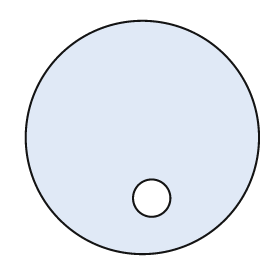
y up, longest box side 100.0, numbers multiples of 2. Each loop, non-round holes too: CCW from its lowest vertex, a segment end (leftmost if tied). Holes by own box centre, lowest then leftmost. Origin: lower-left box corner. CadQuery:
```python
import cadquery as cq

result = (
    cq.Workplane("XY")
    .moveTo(50.0, 50.0)
    .circle(50.0)
    .moveTo(54.0, 24.0)
    .circle(8.0)
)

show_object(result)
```